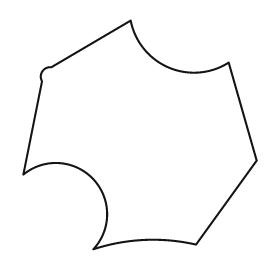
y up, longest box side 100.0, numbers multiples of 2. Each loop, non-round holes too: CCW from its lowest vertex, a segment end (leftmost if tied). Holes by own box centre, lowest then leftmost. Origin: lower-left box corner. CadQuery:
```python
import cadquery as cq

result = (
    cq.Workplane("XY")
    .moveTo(30.0, 0.0)
    .threePointArc((52.0, 4.0), (74.0, 2.0))
    .lineTo(100.0, 38.0)
    .lineTo(88.0, 80.0)
    .threePointArc((62.0, 78.0), (46.0, 98.0))
    .lineTo(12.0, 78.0)
    .threePointArc((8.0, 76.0), (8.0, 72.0))
    .lineTo(0.0, 32.0)
    .threePointArc((30.0, 30.0), (30.0, 0.0))
    .close()
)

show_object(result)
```